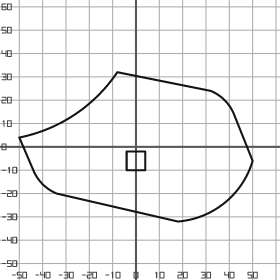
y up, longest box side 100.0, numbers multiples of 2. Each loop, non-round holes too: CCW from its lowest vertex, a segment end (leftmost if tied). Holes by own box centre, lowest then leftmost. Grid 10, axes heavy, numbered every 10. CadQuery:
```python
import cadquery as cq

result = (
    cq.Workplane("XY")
    .moveTo(18.0, -32.0)
    .threePointArc((38.0, -24.0), (50.0, -6.0))
    .lineTo(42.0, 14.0)
    .threePointArc((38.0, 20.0), (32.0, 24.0))
    .lineTo(-8.0, 32.0)
    .threePointArc((-26.0, 14.0), (-50.0, 4.0))
    .lineTo(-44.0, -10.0)
    .threePointArc((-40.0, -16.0), (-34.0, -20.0))
    .close()
    .moveTo(-4.0, -10.0)
    .lineTo(4.0, -10.0)
    .lineTo(4.0, -2.0)
    .lineTo(-4.0, -2.0)
    .close()
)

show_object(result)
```